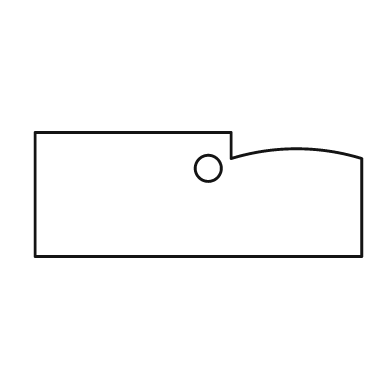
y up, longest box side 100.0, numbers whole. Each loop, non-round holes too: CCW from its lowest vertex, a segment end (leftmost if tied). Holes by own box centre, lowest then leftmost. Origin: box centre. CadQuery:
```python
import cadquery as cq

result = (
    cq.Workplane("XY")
    .moveTo(-50.0, -19.0)
    .lineTo(50.0, -19.0)
    .lineTo(50.0, 11.0)
    .threePointArc((30.0, 14.0), (10.0, 11.0))
    .lineTo(10.0, 19.0)
    .lineTo(-50.0, 19.0)
    .close()
    .moveTo(3.0, 8.0)
    .circle(4.0)
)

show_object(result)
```